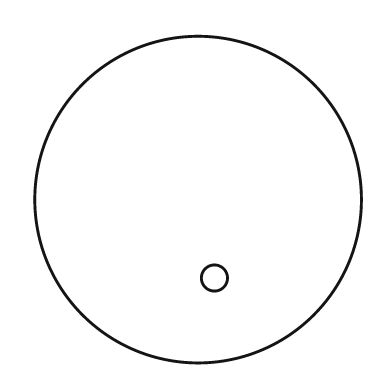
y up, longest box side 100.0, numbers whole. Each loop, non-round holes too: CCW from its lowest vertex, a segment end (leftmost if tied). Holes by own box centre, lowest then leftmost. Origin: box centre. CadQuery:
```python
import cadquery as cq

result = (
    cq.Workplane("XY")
    .moveTo(0.0, 0.0)
    .circle(50.0)
    .moveTo(5.0, -24.0)
    .circle(4.0)
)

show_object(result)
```